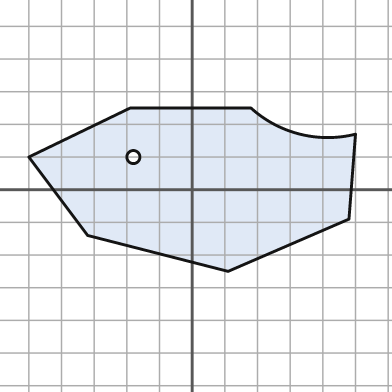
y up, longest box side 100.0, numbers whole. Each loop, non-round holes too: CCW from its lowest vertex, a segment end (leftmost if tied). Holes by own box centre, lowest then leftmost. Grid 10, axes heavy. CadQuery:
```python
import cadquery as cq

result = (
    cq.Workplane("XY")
    .moveTo(11.0, -25.0)
    .lineTo(48.0, -9.0)
    .lineTo(50.0, 17.0)
    .threePointArc((33.0, 17.0), (18.0, 25.0))
    .lineTo(-19.0, 25.0)
    .lineTo(-50.0, 10.0)
    .lineTo(-32.0, -14.0)
    .close()
    .moveTo(-18.0, 10.0)
    .circle(2.0)
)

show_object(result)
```